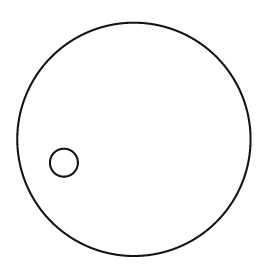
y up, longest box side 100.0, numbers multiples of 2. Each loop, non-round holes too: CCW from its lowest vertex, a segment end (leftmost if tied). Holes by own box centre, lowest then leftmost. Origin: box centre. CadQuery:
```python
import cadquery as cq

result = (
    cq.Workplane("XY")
    .moveTo(0.0, 0.0)
    .circle(50.0)
    .moveTo(-30.0, -10.0)
    .circle(6.0)
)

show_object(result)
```